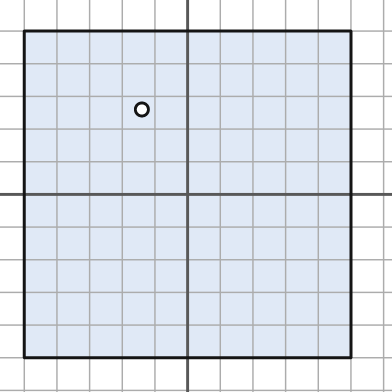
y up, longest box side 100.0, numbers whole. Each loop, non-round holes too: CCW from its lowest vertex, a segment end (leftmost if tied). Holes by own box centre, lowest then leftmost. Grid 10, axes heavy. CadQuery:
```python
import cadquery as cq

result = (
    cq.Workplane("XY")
    .moveTo(-50.0, -50.0)
    .lineTo(50.0, -50.0)
    .lineTo(50.0, 50.0)
    .lineTo(-50.0, 50.0)
    .close()
    .moveTo(-14.0, 26.0)
    .circle(2.0)
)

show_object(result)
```